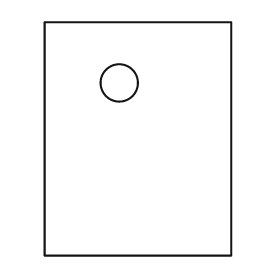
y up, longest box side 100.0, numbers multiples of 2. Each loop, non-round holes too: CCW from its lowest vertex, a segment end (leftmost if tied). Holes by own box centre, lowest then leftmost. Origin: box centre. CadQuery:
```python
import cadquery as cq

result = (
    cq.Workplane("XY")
    .moveTo(-40.0, -50.0)
    .lineTo(40.0, -50.0)
    .lineTo(40.0, 50.0)
    .lineTo(-40.0, 50.0)
    .close()
    .moveTo(-8.0, 24.0)
    .circle(8.0)
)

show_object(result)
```